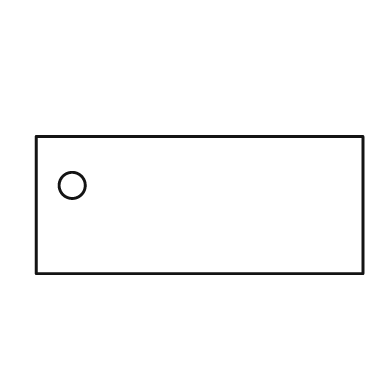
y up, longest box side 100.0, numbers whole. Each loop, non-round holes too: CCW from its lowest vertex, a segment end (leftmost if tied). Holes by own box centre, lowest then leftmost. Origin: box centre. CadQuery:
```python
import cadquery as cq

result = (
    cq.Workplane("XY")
    .moveTo(-50.0, -21.0)
    .lineTo(50.0, -21.0)
    .lineTo(50.0, 21.0)
    .lineTo(-50.0, 21.0)
    .close()
    .moveTo(-39.0, 6.0)
    .circle(4.0)
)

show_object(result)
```